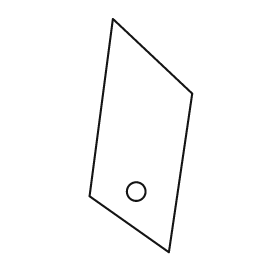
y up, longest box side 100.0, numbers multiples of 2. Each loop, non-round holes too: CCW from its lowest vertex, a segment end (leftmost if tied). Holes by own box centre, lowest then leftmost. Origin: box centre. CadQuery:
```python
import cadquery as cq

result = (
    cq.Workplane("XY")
    .moveTo(12.0, -50.0)
    .lineTo(22.0, 18.0)
    .lineTo(-12.0, 50.0)
    .lineTo(-22.0, -26.0)
    .close()
    .moveTo(-2.0, -24.0)
    .circle(4.0)
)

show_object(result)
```